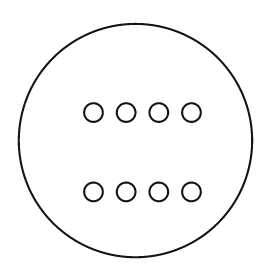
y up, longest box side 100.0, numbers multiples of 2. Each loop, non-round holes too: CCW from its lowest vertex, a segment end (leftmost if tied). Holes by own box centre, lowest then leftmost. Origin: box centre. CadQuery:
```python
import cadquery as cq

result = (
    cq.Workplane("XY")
    .moveTo(0.0, 0.0)
    .circle(50.0)
    .moveTo(-18.0, -22.0)
    .circle(4.0)
    .moveTo(-4.0, -22.0)
    .circle(4.0)
    .moveTo(10.0, -22.0)
    .circle(4.0)
    .moveTo(24.0, -22.0)
    .circle(4.0)
    .moveTo(-18.0, 12.0)
    .circle(4.0)
    .moveTo(-4.0, 12.0)
    .circle(4.0)
    .moveTo(10.0, 12.0)
    .circle(4.0)
    .moveTo(24.0, 12.0)
    .circle(4.0)
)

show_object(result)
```